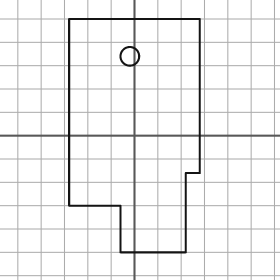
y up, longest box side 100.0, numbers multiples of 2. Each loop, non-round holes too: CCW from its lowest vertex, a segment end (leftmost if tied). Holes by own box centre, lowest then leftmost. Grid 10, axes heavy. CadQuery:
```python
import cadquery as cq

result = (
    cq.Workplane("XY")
    .moveTo(-6.0, -50.0)
    .lineTo(22.0, -50.0)
    .lineTo(22.0, -16.0)
    .lineTo(28.0, -16.0)
    .lineTo(28.0, 50.0)
    .lineTo(-28.0, 50.0)
    .lineTo(-28.0, -30.0)
    .lineTo(-6.0, -30.0)
    .close()
    .moveTo(-2.0, 34.0)
    .circle(4.0)
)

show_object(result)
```